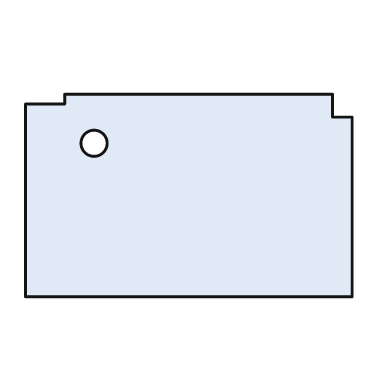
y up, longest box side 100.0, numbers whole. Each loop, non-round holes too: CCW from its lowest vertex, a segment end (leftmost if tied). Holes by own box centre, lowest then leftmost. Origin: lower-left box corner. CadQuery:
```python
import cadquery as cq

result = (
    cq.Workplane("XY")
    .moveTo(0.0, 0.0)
    .lineTo(100.0, 0.0)
    .lineTo(100.0, 55.0)
    .lineTo(94.0, 55.0)
    .lineTo(94.0, 62.0)
    .lineTo(12.0, 62.0)
    .lineTo(12.0, 59.0)
    .lineTo(0.0, 59.0)
    .close()
    .moveTo(21.0, 47.0)
    .circle(4.0)
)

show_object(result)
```